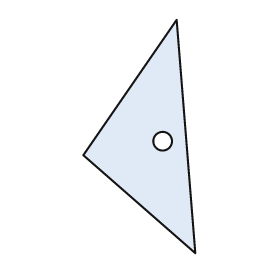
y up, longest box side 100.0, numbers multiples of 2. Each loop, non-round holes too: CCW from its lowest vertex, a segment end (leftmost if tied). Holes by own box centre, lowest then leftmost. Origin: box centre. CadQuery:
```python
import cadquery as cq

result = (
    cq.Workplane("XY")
    .moveTo(24.0, -50.0)
    .lineTo(16.0, 50.0)
    .lineTo(-24.0, -8.0)
    .close()
    .moveTo(10.0, -2.0)
    .circle(4.0)
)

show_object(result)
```